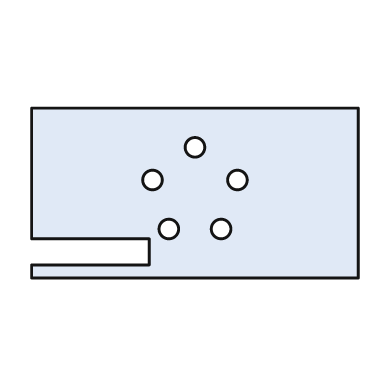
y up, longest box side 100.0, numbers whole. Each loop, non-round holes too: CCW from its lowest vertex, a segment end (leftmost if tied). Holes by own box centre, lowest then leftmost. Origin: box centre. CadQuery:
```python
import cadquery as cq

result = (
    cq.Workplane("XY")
    .moveTo(-50.0, -26.0)
    .lineTo(50.0, -26.0)
    .lineTo(50.0, 26.0)
    .lineTo(-50.0, 26.0)
    .lineTo(-50.0, -14.0)
    .lineTo(-14.0, -14.0)
    .lineTo(-14.0, -22.0)
    .lineTo(-50.0, -22.0)
    .close()
    .moveTo(-8.0, -11.0)
    .circle(3.0)
    .moveTo(8.0, -11.0)
    .circle(3.0)
    .moveTo(-13.0, 4.0)
    .circle(3.0)
    .moveTo(13.0, 4.0)
    .circle(3.0)
    .moveTo(0.0, 14.0)
    .circle(3.0)
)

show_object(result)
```